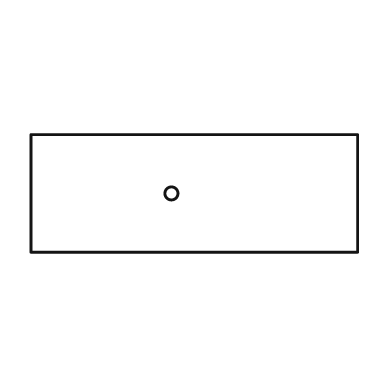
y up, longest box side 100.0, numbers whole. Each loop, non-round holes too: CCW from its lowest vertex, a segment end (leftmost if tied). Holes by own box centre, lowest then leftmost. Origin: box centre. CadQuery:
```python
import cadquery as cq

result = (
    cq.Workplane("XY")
    .moveTo(-50.0, -18.0)
    .lineTo(50.0, -18.0)
    .lineTo(50.0, 18.0)
    .lineTo(-50.0, 18.0)
    .close()
    .moveTo(-7.0, 0.0)
    .circle(2.0)
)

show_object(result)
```